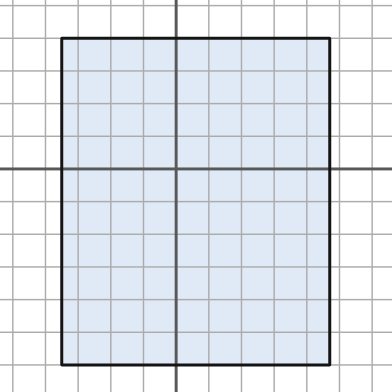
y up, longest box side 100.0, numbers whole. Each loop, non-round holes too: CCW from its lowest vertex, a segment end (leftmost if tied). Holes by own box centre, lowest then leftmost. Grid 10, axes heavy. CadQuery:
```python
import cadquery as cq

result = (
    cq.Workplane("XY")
    .moveTo(-35.0, -60.0)
    .lineTo(47.0, -60.0)
    .lineTo(47.0, 40.0)
    .lineTo(-35.0, 40.0)
    .close()
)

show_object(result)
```